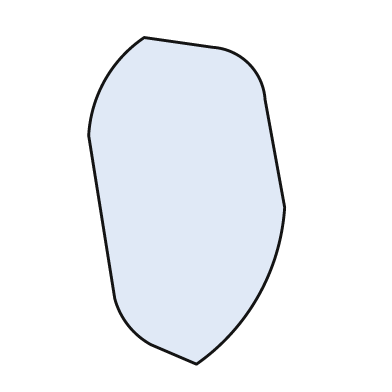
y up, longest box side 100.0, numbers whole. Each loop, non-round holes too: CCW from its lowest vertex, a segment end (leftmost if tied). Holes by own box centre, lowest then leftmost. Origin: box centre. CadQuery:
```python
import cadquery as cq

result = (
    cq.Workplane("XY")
    .moveTo(3.0, -50.0)
    .threePointArc((22.0, -29.0), (30.0, -2.0))
    .lineTo(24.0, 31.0)
    .threePointArc((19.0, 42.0), (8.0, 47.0))
    .lineTo(-13.0, 50.0)
    .threePointArc((-25.0, 37.0), (-30.0, 20.0))
    .lineTo(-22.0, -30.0)
    .threePointArc((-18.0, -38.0), (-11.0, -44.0))
    .close()
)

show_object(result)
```